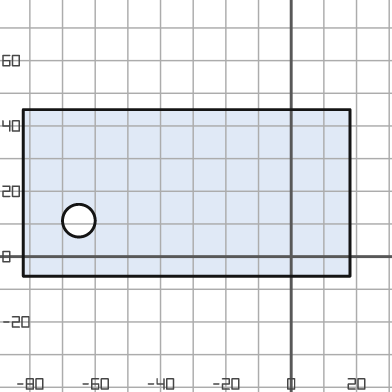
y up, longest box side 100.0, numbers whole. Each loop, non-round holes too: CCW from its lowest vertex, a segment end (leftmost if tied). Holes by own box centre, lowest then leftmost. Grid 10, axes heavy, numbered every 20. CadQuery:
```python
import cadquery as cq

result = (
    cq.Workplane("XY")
    .moveTo(-82.0, -6.0)
    .lineTo(18.0, -6.0)
    .lineTo(18.0, 45.0)
    .lineTo(-82.0, 45.0)
    .close()
    .moveTo(-65.0, 11.0)
    .circle(5.0)
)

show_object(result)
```